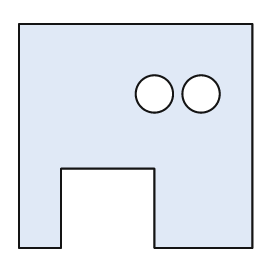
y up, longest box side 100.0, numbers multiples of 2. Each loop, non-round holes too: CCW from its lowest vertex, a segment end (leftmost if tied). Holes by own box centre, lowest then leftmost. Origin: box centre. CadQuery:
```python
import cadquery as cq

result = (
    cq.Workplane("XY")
    .moveTo(-50.0, -48.0)
    .lineTo(-32.0, -48.0)
    .lineTo(-32.0, -14.0)
    .lineTo(8.0, -14.0)
    .lineTo(8.0, -48.0)
    .lineTo(50.0, -48.0)
    .lineTo(50.0, 48.0)
    .lineTo(-50.0, 48.0)
    .close()
    .moveTo(8.0, 18.0)
    .circle(8.0)
    .moveTo(28.0, 18.0)
    .circle(8.0)
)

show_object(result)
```